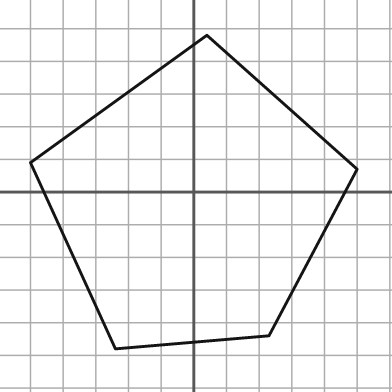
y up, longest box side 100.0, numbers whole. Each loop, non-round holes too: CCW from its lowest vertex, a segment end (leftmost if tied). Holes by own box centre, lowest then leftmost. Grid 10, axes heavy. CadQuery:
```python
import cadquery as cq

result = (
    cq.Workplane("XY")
    .moveTo(-24.0, -48.0)
    .lineTo(23.0, -44.0)
    .lineTo(50.0, 7.0)
    .lineTo(4.0, 48.0)
    .lineTo(-50.0, 9.0)
    .close()
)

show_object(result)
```